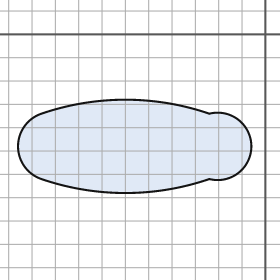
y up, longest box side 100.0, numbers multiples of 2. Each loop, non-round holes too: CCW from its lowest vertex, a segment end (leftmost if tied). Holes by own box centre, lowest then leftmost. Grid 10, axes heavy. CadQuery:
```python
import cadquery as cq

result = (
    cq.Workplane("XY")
    .moveTo(-96.0, -62.0)
    .threePointArc((-60.0, -68.0), (-24.0, -62.0))
    .threePointArc((-6.0, -48.0), (-24.0, -34.0))
    .threePointArc((-60.0, -28.0), (-96.0, -34.0))
    .threePointArc((-106.0, -48.0), (-96.0, -62.0))
    .close()
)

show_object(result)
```